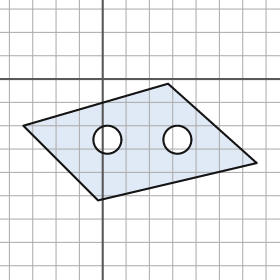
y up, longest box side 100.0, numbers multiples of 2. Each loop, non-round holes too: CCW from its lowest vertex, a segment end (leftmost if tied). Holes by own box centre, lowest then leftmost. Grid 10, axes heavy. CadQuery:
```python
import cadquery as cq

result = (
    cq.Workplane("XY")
    .moveTo(-2.0, -52.0)
    .lineTo(66.0, -36.0)
    .lineTo(28.0, -2.0)
    .lineTo(-34.0, -20.0)
    .close()
    .moveTo(2.0, -26.0)
    .circle(6.0)
    .moveTo(32.0, -26.0)
    .circle(6.0)
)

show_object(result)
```